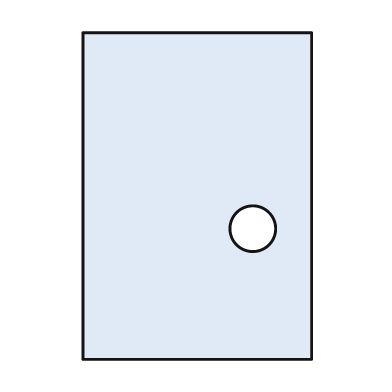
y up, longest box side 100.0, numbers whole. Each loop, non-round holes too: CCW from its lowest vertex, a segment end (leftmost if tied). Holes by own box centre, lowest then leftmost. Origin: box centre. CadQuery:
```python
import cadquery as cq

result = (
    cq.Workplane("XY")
    .moveTo(-35.0, -50.0)
    .lineTo(35.0, -50.0)
    .lineTo(35.0, 50.0)
    .lineTo(-35.0, 50.0)
    .close()
    .moveTo(17.0, -10.0)
    .circle(7.0)
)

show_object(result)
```